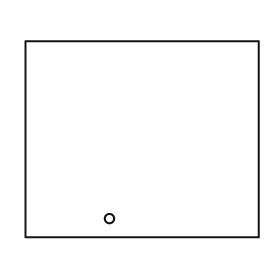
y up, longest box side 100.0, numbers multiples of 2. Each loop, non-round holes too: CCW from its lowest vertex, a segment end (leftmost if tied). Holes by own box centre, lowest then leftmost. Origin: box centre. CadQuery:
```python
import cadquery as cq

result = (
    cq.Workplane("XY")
    .moveTo(-50.0, -42.0)
    .lineTo(50.0, -42.0)
    .lineTo(50.0, 42.0)
    .lineTo(-50.0, 42.0)
    .close()
    .moveTo(-14.0, -34.0)
    .circle(2.0)
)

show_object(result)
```